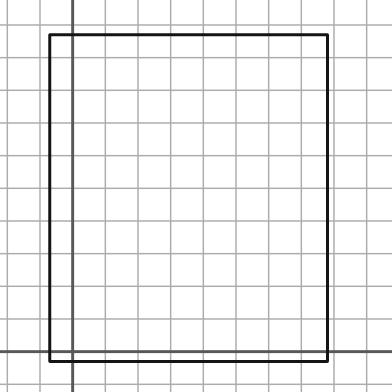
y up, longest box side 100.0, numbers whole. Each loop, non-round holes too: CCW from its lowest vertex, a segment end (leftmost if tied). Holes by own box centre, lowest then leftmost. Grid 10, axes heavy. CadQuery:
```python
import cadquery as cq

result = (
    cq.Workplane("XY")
    .moveTo(-7.0, -3.0)
    .lineTo(78.0, -3.0)
    .lineTo(78.0, 97.0)
    .lineTo(-7.0, 97.0)
    .close()
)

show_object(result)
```